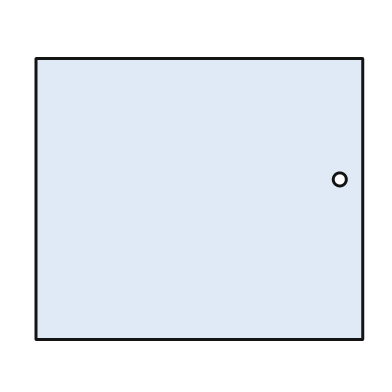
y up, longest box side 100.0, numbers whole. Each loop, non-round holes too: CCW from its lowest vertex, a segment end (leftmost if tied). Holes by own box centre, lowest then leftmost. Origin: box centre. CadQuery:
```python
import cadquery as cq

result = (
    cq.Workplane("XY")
    .moveTo(-50.0, -43.0)
    .lineTo(50.0, -43.0)
    .lineTo(50.0, 43.0)
    .lineTo(-50.0, 43.0)
    .close()
    .moveTo(43.0, 6.0)
    .circle(2.0)
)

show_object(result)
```